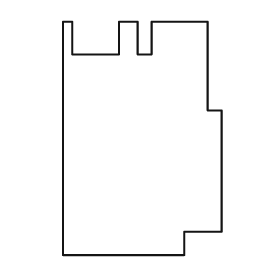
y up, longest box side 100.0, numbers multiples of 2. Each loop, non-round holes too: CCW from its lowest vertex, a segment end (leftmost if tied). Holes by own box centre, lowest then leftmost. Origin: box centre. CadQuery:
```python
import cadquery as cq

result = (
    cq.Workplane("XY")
    .moveTo(-34.0, -50.0)
    .lineTo(18.0, -50.0)
    .lineTo(18.0, -40.0)
    .lineTo(34.0, -40.0)
    .lineTo(34.0, 12.0)
    .lineTo(28.0, 12.0)
    .lineTo(28.0, 50.0)
    .lineTo(4.0, 50.0)
    .lineTo(4.0, 36.0)
    .lineTo(-2.0, 36.0)
    .lineTo(-2.0, 50.0)
    .lineTo(-10.0, 50.0)
    .lineTo(-10.0, 36.0)
    .lineTo(-30.0, 36.0)
    .lineTo(-30.0, 50.0)
    .lineTo(-34.0, 50.0)
    .close()
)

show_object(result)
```